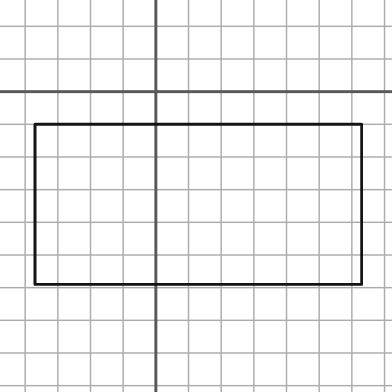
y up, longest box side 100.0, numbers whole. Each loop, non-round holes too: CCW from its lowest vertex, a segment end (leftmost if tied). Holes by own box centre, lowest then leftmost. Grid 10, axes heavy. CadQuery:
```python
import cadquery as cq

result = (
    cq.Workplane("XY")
    .moveTo(-37.0, -59.0)
    .lineTo(63.0, -59.0)
    .lineTo(63.0, -10.0)
    .lineTo(-37.0, -10.0)
    .close()
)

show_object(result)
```